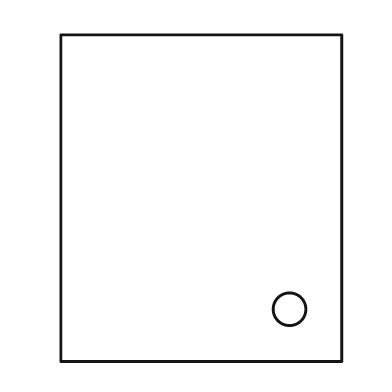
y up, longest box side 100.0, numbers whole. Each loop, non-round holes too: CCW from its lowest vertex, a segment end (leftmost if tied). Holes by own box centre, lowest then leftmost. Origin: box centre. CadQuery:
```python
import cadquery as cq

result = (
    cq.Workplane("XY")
    .moveTo(-43.0, -50.0)
    .lineTo(43.0, -50.0)
    .lineTo(43.0, 50.0)
    .lineTo(-43.0, 50.0)
    .close()
    .moveTo(27.0, -34.0)
    .circle(5.0)
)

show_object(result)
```